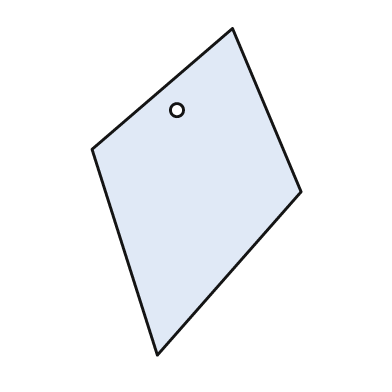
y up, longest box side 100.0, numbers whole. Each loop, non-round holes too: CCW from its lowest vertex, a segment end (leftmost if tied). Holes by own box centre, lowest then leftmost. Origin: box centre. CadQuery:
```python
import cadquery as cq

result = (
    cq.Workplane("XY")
    .moveTo(-12.0, -50.0)
    .lineTo(32.0, 0.0)
    .lineTo(11.0, 50.0)
    .lineTo(-32.0, 13.0)
    .close()
    .moveTo(-6.0, 25.0)
    .circle(2.0)
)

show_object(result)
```